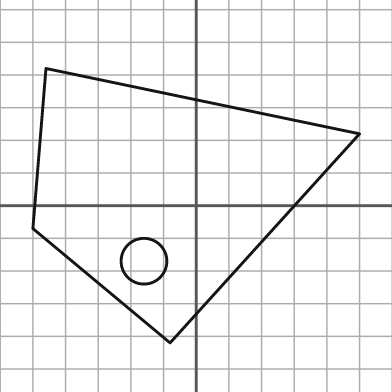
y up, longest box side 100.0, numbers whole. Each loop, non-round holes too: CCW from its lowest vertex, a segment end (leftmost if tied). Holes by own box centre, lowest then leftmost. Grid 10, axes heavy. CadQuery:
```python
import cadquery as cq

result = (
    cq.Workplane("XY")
    .moveTo(-8.0, -42.0)
    .lineTo(50.0, 22.0)
    .lineTo(-46.0, 42.0)
    .lineTo(-50.0, -7.0)
    .close()
    .moveTo(-16.0, -17.0)
    .circle(7.0)
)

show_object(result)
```